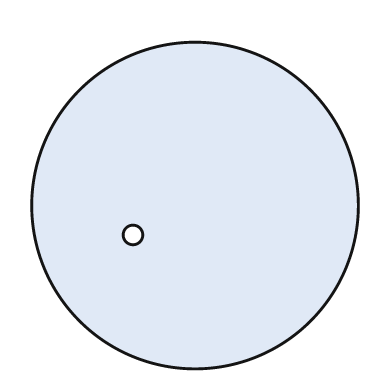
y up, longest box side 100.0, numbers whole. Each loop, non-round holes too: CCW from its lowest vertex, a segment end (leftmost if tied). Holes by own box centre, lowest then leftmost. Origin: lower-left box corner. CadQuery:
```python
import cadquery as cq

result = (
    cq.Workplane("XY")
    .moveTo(50.0, 50.0)
    .circle(50.0)
    .moveTo(31.0, 41.0)
    .circle(3.0)
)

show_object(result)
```